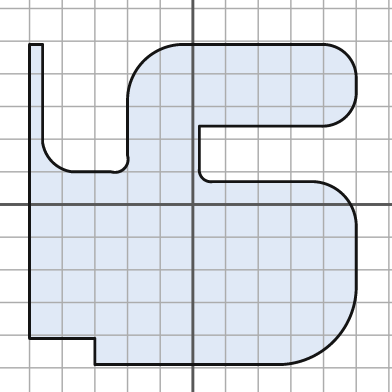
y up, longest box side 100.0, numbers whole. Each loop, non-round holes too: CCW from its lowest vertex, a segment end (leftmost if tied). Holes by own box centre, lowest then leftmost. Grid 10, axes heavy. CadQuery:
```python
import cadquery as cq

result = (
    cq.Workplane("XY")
    .moveTo(-30.0, -49.0)
    .lineTo(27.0, -49.0)
    .threePointArc((43.0, -42.0), (50.0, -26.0))
    .lineTo(50.0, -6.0)
    .threePointArc((46.0, 3.0), (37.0, 7.0))
    .lineTo(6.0, 7.0)
    .threePointArc((3.0, 8.0), (2.0, 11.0))
    .lineTo(2.0, 24.0)
    .lineTo(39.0, 24.0)
    .threePointArc((47.0, 27.0), (50.0, 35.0))
    .lineTo(50.0, 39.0)
    .threePointArc((47.0, 46.0), (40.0, 49.0))
    .lineTo(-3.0, 49.0)
    .threePointArc((-15.0, 44.0), (-20.0, 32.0))
    .lineTo(-20.0, 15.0)
    .threePointArc((-21.0, 11.0), (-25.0, 10.0))
    .lineTo(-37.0, 10.0)
    .threePointArc((-43.0, 13.0), (-46.0, 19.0))
    .lineTo(-46.0, 49.0)
    .lineTo(-50.0, 49.0)
    .lineTo(-50.0, -41.0)
    .lineTo(-30.0, -41.0)
    .close()
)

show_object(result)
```